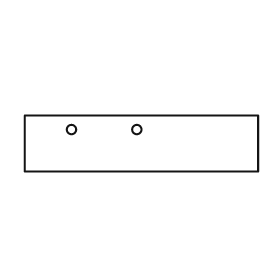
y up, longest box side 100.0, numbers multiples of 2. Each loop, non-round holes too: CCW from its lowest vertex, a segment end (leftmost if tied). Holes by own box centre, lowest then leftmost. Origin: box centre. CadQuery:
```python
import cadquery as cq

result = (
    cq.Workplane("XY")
    .moveTo(-50.0, -12.0)
    .lineTo(50.0, -12.0)
    .lineTo(50.0, 12.0)
    .lineTo(-50.0, 12.0)
    .close()
    .moveTo(-30.0, 6.0)
    .circle(2.0)
    .moveTo(-2.0, 6.0)
    .circle(2.0)
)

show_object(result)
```